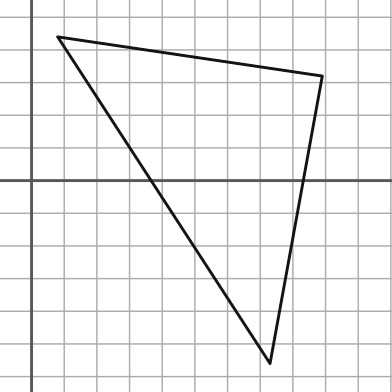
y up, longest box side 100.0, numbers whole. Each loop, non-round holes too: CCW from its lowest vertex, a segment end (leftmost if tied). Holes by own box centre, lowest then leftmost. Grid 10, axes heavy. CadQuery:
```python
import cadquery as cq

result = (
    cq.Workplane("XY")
    .moveTo(73.0, -56.0)
    .lineTo(89.0, 32.0)
    .lineTo(8.0, 44.0)
    .close()
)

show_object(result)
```